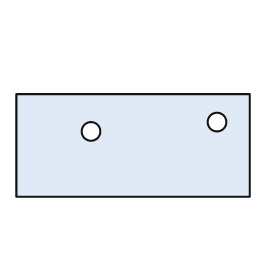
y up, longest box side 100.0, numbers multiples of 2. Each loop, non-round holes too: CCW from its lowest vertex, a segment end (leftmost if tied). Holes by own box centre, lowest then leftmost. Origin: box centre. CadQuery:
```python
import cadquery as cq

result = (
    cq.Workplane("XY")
    .moveTo(-50.0, -22.0)
    .lineTo(50.0, -22.0)
    .lineTo(50.0, 22.0)
    .lineTo(-50.0, 22.0)
    .close()
    .moveTo(-18.0, 6.0)
    .circle(4.0)
    .moveTo(36.0, 10.0)
    .circle(4.0)
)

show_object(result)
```